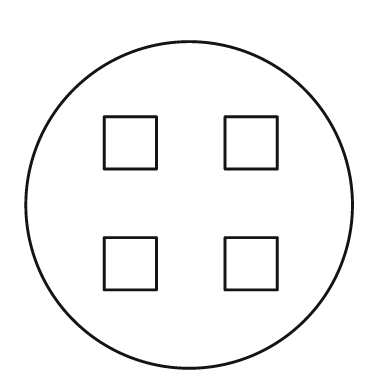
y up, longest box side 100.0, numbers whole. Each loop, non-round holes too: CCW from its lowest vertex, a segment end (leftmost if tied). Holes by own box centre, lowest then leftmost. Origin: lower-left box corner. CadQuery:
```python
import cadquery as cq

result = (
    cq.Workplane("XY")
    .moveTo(50.0, 50.0)
    .circle(50.0)
    .moveTo(24.0, 24.0)
    .lineTo(40.0, 24.0)
    .lineTo(40.0, 40.0)
    .lineTo(24.0, 40.0)
    .close()
    .moveTo(61.0, 24.0)
    .lineTo(77.0, 24.0)
    .lineTo(77.0, 40.0)
    .lineTo(61.0, 40.0)
    .close()
    .moveTo(24.0, 61.0)
    .lineTo(40.0, 61.0)
    .lineTo(40.0, 77.0)
    .lineTo(24.0, 77.0)
    .close()
    .moveTo(61.0, 61.0)
    .lineTo(77.0, 61.0)
    .lineTo(77.0, 77.0)
    .lineTo(61.0, 77.0)
    .close()
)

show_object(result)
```